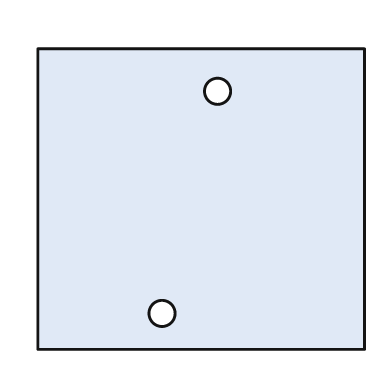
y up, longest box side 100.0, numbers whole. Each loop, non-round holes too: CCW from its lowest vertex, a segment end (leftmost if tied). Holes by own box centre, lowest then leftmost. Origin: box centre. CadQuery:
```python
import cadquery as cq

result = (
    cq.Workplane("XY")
    .moveTo(-50.0, -46.0)
    .lineTo(50.0, -46.0)
    .lineTo(50.0, 46.0)
    .lineTo(-50.0, 46.0)
    .close()
    .moveTo(-12.0, -35.0)
    .circle(4.0)
    .moveTo(5.0, 33.0)
    .circle(4.0)
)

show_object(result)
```